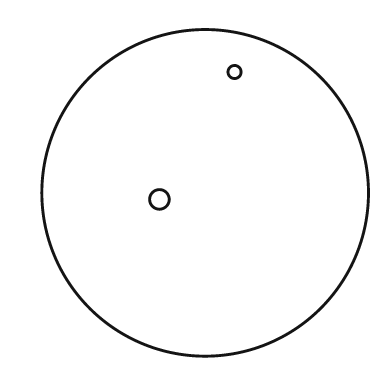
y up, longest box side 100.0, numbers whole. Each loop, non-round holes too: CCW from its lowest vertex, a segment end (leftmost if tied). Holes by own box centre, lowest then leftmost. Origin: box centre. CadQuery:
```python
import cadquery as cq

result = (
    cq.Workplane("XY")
    .moveTo(0.0, 0.0)
    .circle(50.0)
    .moveTo(-14.0, -2.0)
    .circle(3.0)
    .moveTo(9.0, 37.0)
    .circle(2.0)
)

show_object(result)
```